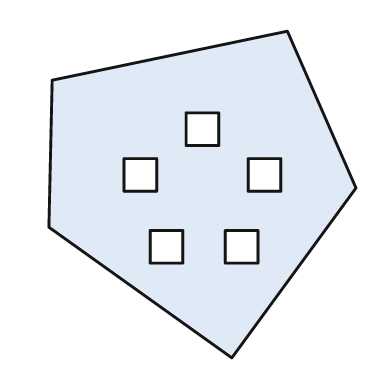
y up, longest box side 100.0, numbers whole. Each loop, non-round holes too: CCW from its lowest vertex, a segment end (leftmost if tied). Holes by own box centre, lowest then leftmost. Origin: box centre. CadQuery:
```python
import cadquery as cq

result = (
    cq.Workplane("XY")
    .moveTo(9.0, -50.0)
    .lineTo(47.0, 2.0)
    .lineTo(26.0, 50.0)
    .lineTo(-46.0, 35.0)
    .lineTo(-47.0, -10.0)
    .close()
    .moveTo(-16.0, -21.0)
    .lineTo(-6.0, -21.0)
    .lineTo(-6.0, -11.0)
    .lineTo(-16.0, -11.0)
    .close()
    .moveTo(7.0, -21.0)
    .lineTo(17.0, -21.0)
    .lineTo(17.0, -11.0)
    .lineTo(7.0, -11.0)
    .close()
    .moveTo(-24.0, 1.0)
    .lineTo(-14.0, 1.0)
    .lineTo(-14.0, 11.0)
    .lineTo(-24.0, 11.0)
    .close()
    .moveTo(14.0, 1.0)
    .lineTo(24.0, 1.0)
    .lineTo(24.0, 11.0)
    .lineTo(14.0, 11.0)
    .close()
    .moveTo(-5.0, 15.0)
    .lineTo(5.0, 15.0)
    .lineTo(5.0, 25.0)
    .lineTo(-5.0, 25.0)
    .close()
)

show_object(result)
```